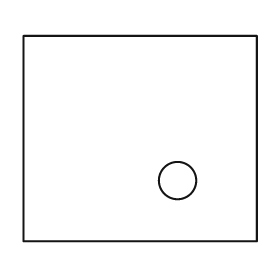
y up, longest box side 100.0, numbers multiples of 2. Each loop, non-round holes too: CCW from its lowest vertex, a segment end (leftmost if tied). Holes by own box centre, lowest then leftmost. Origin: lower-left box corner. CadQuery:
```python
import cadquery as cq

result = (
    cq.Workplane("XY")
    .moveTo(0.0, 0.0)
    .lineTo(100.0, 0.0)
    .lineTo(100.0, 88.0)
    .lineTo(0.0, 88.0)
    .close()
    .moveTo(66.0, 26.0)
    .circle(8.0)
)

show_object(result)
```